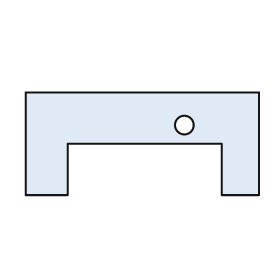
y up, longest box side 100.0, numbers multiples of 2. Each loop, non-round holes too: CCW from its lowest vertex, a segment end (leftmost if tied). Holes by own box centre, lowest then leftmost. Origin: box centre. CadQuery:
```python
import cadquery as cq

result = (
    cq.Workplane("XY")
    .moveTo(-50.0, -22.0)
    .lineTo(-32.0, -22.0)
    .lineTo(-32.0, 0.0)
    .lineTo(34.0, 0.0)
    .lineTo(34.0, -22.0)
    .lineTo(50.0, -22.0)
    .lineTo(50.0, 22.0)
    .lineTo(-50.0, 22.0)
    .close()
    .moveTo(18.0, 8.0)
    .circle(4.0)
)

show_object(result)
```